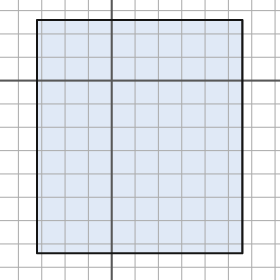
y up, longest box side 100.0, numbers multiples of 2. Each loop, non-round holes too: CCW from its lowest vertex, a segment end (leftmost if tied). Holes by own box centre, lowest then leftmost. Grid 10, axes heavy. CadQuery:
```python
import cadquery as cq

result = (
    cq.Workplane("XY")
    .moveTo(-32.0, -74.0)
    .lineTo(56.0, -74.0)
    .lineTo(56.0, 26.0)
    .lineTo(-32.0, 26.0)
    .close()
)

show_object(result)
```